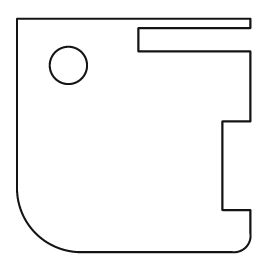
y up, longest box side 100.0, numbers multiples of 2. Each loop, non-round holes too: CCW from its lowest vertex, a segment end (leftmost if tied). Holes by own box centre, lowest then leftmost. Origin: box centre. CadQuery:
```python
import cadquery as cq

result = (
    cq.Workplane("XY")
    .moveTo(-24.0, -50.0)
    .lineTo(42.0, -50.0)
    .threePointArc((48.0, -48.0), (50.0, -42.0))
    .lineTo(50.0, -32.0)
    .lineTo(38.0, -32.0)
    .lineTo(38.0, 6.0)
    .lineTo(50.0, 6.0)
    .lineTo(50.0, 36.0)
    .lineTo(2.0, 36.0)
    .lineTo(2.0, 46.0)
    .lineTo(50.0, 46.0)
    .lineTo(50.0, 50.0)
    .lineTo(-50.0, 50.0)
    .lineTo(-50.0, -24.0)
    .threePointArc((-42.0, -42.0), (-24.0, -50.0))
    .close()
    .moveTo(-28.0, 30.0)
    .circle(8.0)
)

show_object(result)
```